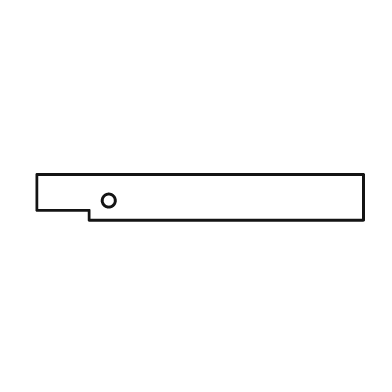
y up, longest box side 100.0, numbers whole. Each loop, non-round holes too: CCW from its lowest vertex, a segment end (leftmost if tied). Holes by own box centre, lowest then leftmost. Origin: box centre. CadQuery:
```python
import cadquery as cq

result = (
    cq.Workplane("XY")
    .moveTo(-34.0, -7.0)
    .lineTo(50.0, -7.0)
    .lineTo(50.0, 7.0)
    .lineTo(-50.0, 7.0)
    .lineTo(-50.0, -4.0)
    .lineTo(-34.0, -4.0)
    .close()
    .moveTo(-28.0, -1.0)
    .circle(2.0)
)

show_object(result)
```